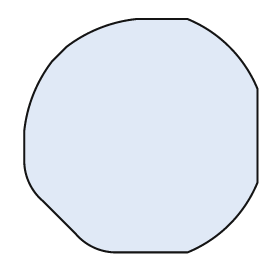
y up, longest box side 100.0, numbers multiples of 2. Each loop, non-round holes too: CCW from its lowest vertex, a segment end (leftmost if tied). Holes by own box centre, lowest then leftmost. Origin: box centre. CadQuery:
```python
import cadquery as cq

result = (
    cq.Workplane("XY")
    .moveTo(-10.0, -50.0)
    .lineTo(20.0, -50.0)
    .threePointArc((38.0, -38.0), (50.0, -20.0))
    .lineTo(50.0, 20.0)
    .threePointArc((38.0, 38.0), (20.0, 50.0))
    .lineTo(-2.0, 50.0)
    .threePointArc((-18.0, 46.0), (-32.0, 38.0))
    .lineTo(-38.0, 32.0)
    .threePointArc((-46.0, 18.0), (-50.0, 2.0))
    .lineTo(-50.0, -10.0)
    .threePointArc((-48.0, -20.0), (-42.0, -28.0))
    .lineTo(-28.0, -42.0)
    .threePointArc((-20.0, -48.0), (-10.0, -50.0))
    .close()
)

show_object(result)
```